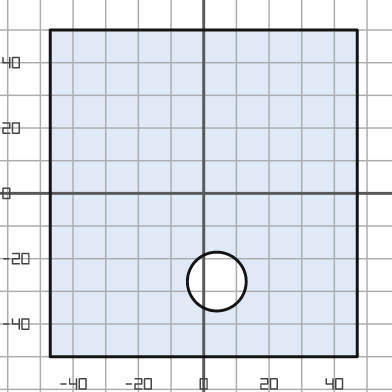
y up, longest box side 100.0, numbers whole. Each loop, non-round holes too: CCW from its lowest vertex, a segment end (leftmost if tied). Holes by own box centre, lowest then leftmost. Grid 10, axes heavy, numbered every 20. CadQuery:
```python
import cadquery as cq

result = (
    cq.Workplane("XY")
    .moveTo(-47.0, -50.0)
    .lineTo(47.0, -50.0)
    .lineTo(47.0, 50.0)
    .lineTo(-47.0, 50.0)
    .close()
    .moveTo(4.0, -27.0)
    .circle(9.0)
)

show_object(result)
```